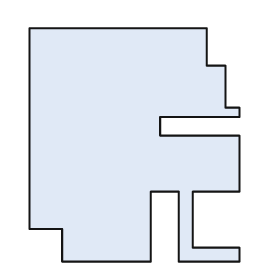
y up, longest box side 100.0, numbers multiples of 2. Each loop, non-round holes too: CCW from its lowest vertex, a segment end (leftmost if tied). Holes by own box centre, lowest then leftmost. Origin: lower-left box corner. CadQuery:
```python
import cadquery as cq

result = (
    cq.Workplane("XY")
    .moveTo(14.0, 0.0)
    .lineTo(52.0, 0.0)
    .lineTo(52.0, 30.0)
    .lineTo(64.0, 30.0)
    .lineTo(64.0, 0.0)
    .lineTo(90.0, 0.0)
    .lineTo(90.0, 6.0)
    .lineTo(70.0, 6.0)
    .lineTo(70.0, 30.0)
    .lineTo(90.0, 30.0)
    .lineTo(90.0, 54.0)
    .lineTo(56.0, 54.0)
    .lineTo(56.0, 62.0)
    .lineTo(90.0, 62.0)
    .lineTo(90.0, 66.0)
    .lineTo(84.0, 66.0)
    .lineTo(84.0, 84.0)
    .lineTo(76.0, 84.0)
    .lineTo(76.0, 100.0)
    .lineTo(0.0, 100.0)
    .lineTo(0.0, 14.0)
    .lineTo(14.0, 14.0)
    .close()
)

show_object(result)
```